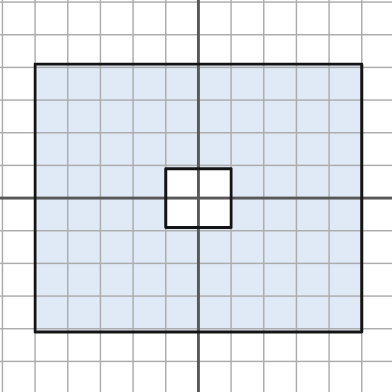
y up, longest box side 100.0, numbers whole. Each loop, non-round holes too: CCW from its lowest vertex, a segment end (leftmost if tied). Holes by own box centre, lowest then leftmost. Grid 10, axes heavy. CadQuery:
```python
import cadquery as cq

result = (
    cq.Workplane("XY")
    .moveTo(-50.0, -41.0)
    .lineTo(50.0, -41.0)
    .lineTo(50.0, 41.0)
    .lineTo(-50.0, 41.0)
    .close()
    .moveTo(-10.0, -9.0)
    .lineTo(10.0, -9.0)
    .lineTo(10.0, 9.0)
    .lineTo(-10.0, 9.0)
    .close()
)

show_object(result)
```